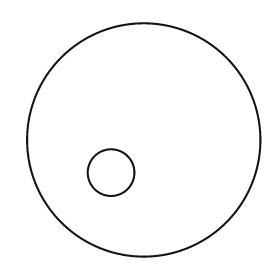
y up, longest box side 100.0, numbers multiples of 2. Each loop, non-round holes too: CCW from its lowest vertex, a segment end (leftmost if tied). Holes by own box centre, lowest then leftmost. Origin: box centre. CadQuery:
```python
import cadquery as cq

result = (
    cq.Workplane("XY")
    .moveTo(0.0, 0.0)
    .circle(50.0)
    .moveTo(-14.0, -14.0)
    .circle(10.0)
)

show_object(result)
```